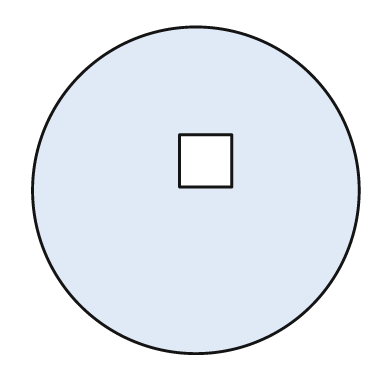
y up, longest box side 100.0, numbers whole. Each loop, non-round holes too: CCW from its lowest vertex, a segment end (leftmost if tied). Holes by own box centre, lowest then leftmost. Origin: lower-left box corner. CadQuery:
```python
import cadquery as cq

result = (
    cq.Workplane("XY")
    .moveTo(50.0, 50.0)
    .circle(50.0)
    .moveTo(45.0, 51.0)
    .lineTo(61.0, 51.0)
    .lineTo(61.0, 67.0)
    .lineTo(45.0, 67.0)
    .close()
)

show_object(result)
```